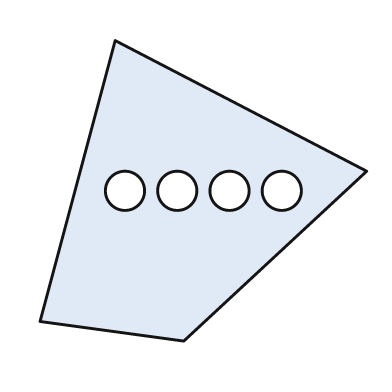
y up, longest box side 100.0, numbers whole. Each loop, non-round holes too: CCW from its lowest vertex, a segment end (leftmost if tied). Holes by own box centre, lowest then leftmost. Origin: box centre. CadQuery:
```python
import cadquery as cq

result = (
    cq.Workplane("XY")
    .moveTo(-6.0, -46.0)
    .lineTo(50.0, 6.0)
    .lineTo(-27.0, 46.0)
    .lineTo(-50.0, -40.0)
    .close()
    .moveTo(-24.0, 0.0)
    .circle(6.0)
    .moveTo(-8.0, 0.0)
    .circle(6.0)
    .moveTo(8.0, 0.0)
    .circle(6.0)
    .moveTo(24.0, 0.0)
    .circle(6.0)
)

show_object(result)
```